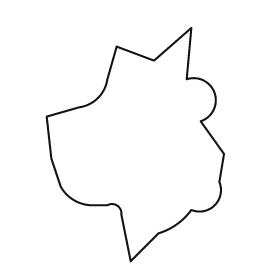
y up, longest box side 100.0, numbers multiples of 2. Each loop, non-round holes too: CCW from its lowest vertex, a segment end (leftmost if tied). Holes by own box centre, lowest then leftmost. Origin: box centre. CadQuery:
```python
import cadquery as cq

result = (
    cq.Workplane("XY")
    .moveTo(-2.0, -50.0)
    .lineTo(10.0, -38.0)
    .threePointArc((18.0, -34.0), (24.0, -28.0))
    .threePointArc((34.0, -26.0), (36.0, -16.0))
    .lineTo(38.0, -4.0)
    .lineTo(28.0, 10.0)
    .threePointArc((34.0, 22.0), (22.0, 28.0))
    .lineTo(24.0, 50.0)
    .lineTo(8.0, 36.0)
    .lineTo(-8.0, 42.0)
    .lineTo(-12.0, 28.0)
    .threePointArc((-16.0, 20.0), (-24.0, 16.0))
    .lineTo(-38.0, 12.0)
    .lineTo(-36.0, -6.0)
    .lineTo(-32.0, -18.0)
    .threePointArc((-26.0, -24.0), (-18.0, -26.0))
    .lineTo(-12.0, -26.0)
    .threePointArc((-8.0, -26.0), (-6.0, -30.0))
    .close()
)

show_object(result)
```